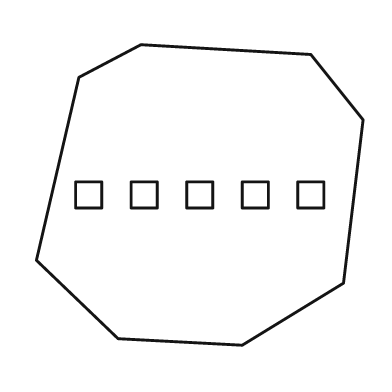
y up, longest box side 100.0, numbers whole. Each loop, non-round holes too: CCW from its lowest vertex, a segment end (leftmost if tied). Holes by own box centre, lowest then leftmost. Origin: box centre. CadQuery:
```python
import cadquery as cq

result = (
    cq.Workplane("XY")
    .moveTo(13.0, -46.0)
    .lineTo(44.0, -27.0)
    .lineTo(50.0, 23.0)
    .lineTo(34.0, 43.0)
    .lineTo(-18.0, 46.0)
    .lineTo(-37.0, 36.0)
    .lineTo(-50.0, -20.0)
    .lineTo(-25.0, -44.0)
    .close()
    .moveTo(-38.0, -4.0)
    .lineTo(-30.0, -4.0)
    .lineTo(-30.0, 4.0)
    .lineTo(-38.0, 4.0)
    .close()
    .moveTo(-21.0, -4.0)
    .lineTo(-13.0, -4.0)
    .lineTo(-13.0, 4.0)
    .lineTo(-21.0, 4.0)
    .close()
    .moveTo(-4.0, -4.0)
    .lineTo(4.0, -4.0)
    .lineTo(4.0, 4.0)
    .lineTo(-4.0, 4.0)
    .close()
    .moveTo(13.0, -4.0)
    .lineTo(21.0, -4.0)
    .lineTo(21.0, 4.0)
    .lineTo(13.0, 4.0)
    .close()
    .moveTo(30.0, -4.0)
    .lineTo(38.0, -4.0)
    .lineTo(38.0, 4.0)
    .lineTo(30.0, 4.0)
    .close()
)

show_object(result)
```